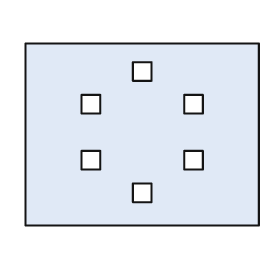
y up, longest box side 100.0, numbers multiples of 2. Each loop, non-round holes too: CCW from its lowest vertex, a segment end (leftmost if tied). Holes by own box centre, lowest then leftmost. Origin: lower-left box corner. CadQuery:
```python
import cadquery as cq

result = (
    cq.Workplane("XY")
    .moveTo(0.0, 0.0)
    .lineTo(100.0, 0.0)
    .lineTo(100.0, 78.0)
    .lineTo(0.0, 78.0)
    .close()
    .moveTo(46.0, 10.0)
    .lineTo(54.0, 10.0)
    .lineTo(54.0, 18.0)
    .lineTo(46.0, 18.0)
    .close()
    .moveTo(24.0, 24.0)
    .lineTo(32.0, 24.0)
    .lineTo(32.0, 32.0)
    .lineTo(24.0, 32.0)
    .close()
    .moveTo(68.0, 24.0)
    .lineTo(76.0, 24.0)
    .lineTo(76.0, 32.0)
    .lineTo(68.0, 32.0)
    .close()
    .moveTo(24.0, 48.0)
    .lineTo(32.0, 48.0)
    .lineTo(32.0, 56.0)
    .lineTo(24.0, 56.0)
    .close()
    .moveTo(68.0, 48.0)
    .lineTo(76.0, 48.0)
    .lineTo(76.0, 56.0)
    .lineTo(68.0, 56.0)
    .close()
    .moveTo(46.0, 62.0)
    .lineTo(54.0, 62.0)
    .lineTo(54.0, 70.0)
    .lineTo(46.0, 70.0)
    .close()
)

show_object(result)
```